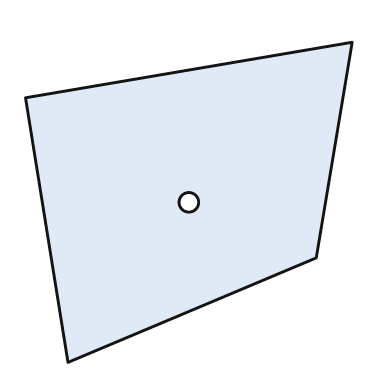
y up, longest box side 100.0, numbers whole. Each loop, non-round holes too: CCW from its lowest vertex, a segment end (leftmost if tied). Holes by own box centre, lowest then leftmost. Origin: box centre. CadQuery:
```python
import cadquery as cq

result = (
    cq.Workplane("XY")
    .moveTo(-37.0, -49.0)
    .lineTo(39.0, -17.0)
    .lineTo(50.0, 49.0)
    .lineTo(-50.0, 32.0)
    .close()
    .moveTo(0.0, 0.0)
    .circle(3.0)
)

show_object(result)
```